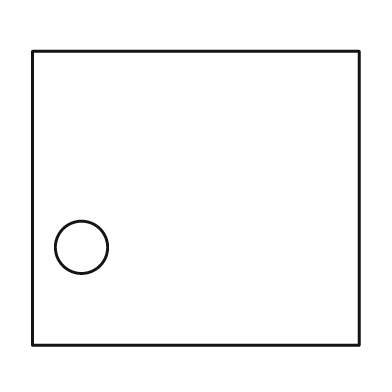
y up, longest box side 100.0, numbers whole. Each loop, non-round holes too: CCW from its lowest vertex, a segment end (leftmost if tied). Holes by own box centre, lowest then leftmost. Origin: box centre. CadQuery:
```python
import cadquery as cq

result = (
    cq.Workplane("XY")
    .moveTo(-50.0, -45.0)
    .lineTo(50.0, -45.0)
    .lineTo(50.0, 45.0)
    .lineTo(-50.0, 45.0)
    .close()
    .moveTo(-35.0, -15.0)
    .circle(8.0)
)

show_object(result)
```